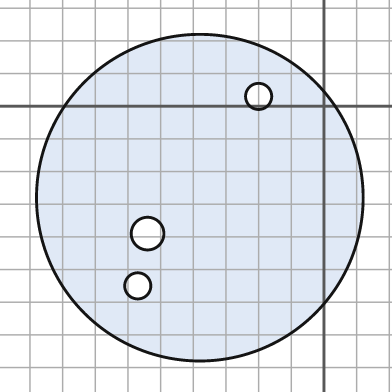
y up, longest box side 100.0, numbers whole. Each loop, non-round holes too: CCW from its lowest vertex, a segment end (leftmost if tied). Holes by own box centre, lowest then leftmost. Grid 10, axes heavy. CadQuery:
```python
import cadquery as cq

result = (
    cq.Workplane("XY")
    .moveTo(-38.0, -28.0)
    .circle(50.0)
    .moveTo(-57.0, -55.0)
    .circle(4.0)
    .moveTo(-54.0, -39.0)
    .circle(5.0)
    .moveTo(-20.0, 3.0)
    .circle(4.0)
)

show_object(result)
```